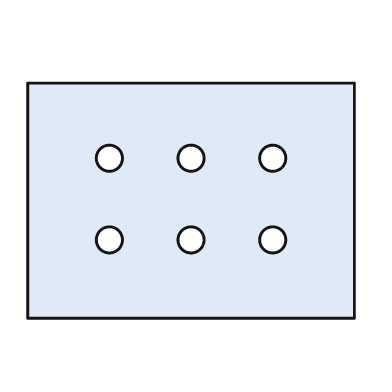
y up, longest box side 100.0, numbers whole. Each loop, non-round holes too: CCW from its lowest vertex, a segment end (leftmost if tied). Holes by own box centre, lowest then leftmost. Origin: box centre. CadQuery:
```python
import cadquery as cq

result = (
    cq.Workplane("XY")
    .moveTo(-50.0, -36.0)
    .lineTo(50.0, -36.0)
    .lineTo(50.0, 36.0)
    .lineTo(-50.0, 36.0)
    .close()
    .moveTo(-25.0, -12.0)
    .circle(4.0)
    .moveTo(0.0, -12.0)
    .circle(4.0)
    .moveTo(25.0, -12.0)
    .circle(4.0)
    .moveTo(-25.0, 13.0)
    .circle(4.0)
    .moveTo(0.0, 13.0)
    .circle(4.0)
    .moveTo(25.0, 13.0)
    .circle(4.0)
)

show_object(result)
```